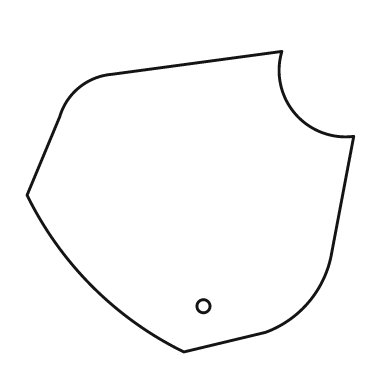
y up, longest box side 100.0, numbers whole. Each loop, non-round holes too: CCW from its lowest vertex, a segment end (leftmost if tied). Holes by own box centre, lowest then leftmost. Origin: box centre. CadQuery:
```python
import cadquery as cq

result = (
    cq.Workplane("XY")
    .moveTo(-2.0, -46.0)
    .lineTo(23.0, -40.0)
    .threePointArc((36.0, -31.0), (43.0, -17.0))
    .lineTo(50.0, 20.0)
    .threePointArc((32.0, 27.0), (28.0, 46.0))
    .lineTo(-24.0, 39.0)
    .threePointArc((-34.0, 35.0), (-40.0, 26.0))
    .lineTo(-50.0, 2.0)
    .threePointArc((-30.0, -26.0), (-2.0, -46.0))
    .close()
    .moveTo(4.0, -32.0)
    .circle(2.0)
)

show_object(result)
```